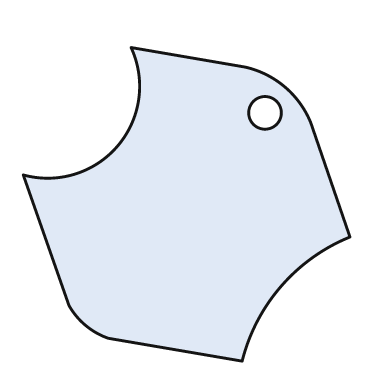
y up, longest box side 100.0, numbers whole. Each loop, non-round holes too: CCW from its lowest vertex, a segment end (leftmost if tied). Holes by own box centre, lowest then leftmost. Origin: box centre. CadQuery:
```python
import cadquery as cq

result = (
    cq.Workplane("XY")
    .moveTo(17.0, -48.0)
    .threePointArc((29.0, -25.0), (50.0, -10.0))
    .lineTo(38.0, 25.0)
    .threePointArc((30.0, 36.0), (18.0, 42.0))
    .lineTo(-17.0, 48.0)
    .threePointArc((-21.0, 18.0), (-50.0, 9.0))
    .lineTo(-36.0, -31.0)
    .threePointArc((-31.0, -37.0), (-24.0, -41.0))
    .close()
    .moveTo(24.0, 28.0)
    .circle(5.0)
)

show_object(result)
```